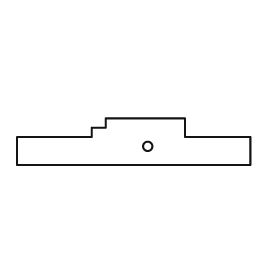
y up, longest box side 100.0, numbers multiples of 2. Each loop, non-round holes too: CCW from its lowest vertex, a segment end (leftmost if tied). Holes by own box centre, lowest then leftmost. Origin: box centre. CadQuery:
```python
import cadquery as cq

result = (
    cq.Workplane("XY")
    .moveTo(-50.0, -10.0)
    .lineTo(50.0, -10.0)
    .lineTo(50.0, 2.0)
    .lineTo(22.0, 2.0)
    .lineTo(22.0, 10.0)
    .lineTo(-12.0, 10.0)
    .lineTo(-12.0, 6.0)
    .lineTo(-18.0, 6.0)
    .lineTo(-18.0, 2.0)
    .lineTo(-50.0, 2.0)
    .close()
    .moveTo(6.0, -2.0)
    .circle(2.0)
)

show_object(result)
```